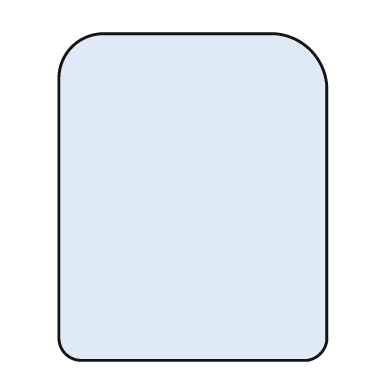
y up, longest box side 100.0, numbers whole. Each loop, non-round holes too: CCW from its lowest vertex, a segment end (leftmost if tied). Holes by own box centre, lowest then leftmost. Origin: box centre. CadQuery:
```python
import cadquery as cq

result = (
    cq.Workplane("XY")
    .moveTo(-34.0, -50.0)
    .lineTo(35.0, -50.0)
    .threePointArc((39.0, -48.0), (41.0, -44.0))
    .lineTo(41.0, 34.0)
    .threePointArc((36.0, 45.0), (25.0, 50.0))
    .lineTo(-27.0, 50.0)
    .threePointArc((-37.0, 46.0), (-41.0, 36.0))
    .lineTo(-41.0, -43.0)
    .threePointArc((-39.0, -48.0), (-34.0, -50.0))
    .close()
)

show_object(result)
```